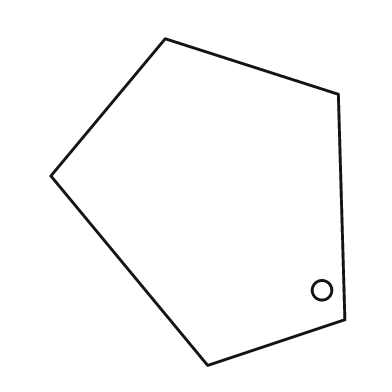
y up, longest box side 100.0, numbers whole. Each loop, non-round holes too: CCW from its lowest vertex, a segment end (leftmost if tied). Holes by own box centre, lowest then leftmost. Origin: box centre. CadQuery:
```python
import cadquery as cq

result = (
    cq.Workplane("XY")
    .moveTo(3.0, -50.0)
    .lineTo(45.0, -36.0)
    .lineTo(43.0, 33.0)
    .lineTo(-10.0, 50.0)
    .lineTo(-45.0, 8.0)
    .close()
    .moveTo(38.0, -27.0)
    .circle(3.0)
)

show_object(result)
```